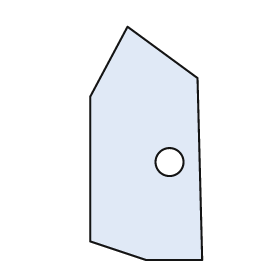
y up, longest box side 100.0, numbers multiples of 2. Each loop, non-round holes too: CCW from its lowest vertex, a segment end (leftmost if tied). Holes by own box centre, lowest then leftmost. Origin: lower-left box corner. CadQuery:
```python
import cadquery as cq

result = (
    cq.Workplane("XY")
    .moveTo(24.0, 0.0)
    .lineTo(48.0, 0.0)
    .lineTo(46.0, 78.0)
    .lineTo(16.0, 100.0)
    .lineTo(0.0, 70.0)
    .lineTo(0.0, 8.0)
    .close()
    .moveTo(34.0, 42.0)
    .circle(6.0)
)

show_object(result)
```